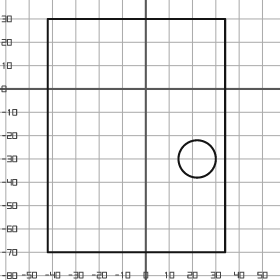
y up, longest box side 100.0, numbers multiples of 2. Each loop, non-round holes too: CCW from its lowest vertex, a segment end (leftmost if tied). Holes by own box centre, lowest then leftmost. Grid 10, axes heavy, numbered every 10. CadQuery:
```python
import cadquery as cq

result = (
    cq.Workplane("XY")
    .moveTo(-42.0, -70.0)
    .lineTo(34.0, -70.0)
    .lineTo(34.0, 30.0)
    .lineTo(-42.0, 30.0)
    .close()
    .moveTo(22.0, -30.0)
    .circle(8.0)
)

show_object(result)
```